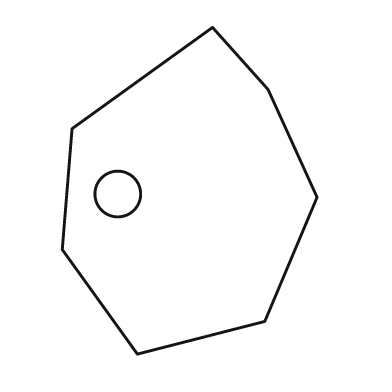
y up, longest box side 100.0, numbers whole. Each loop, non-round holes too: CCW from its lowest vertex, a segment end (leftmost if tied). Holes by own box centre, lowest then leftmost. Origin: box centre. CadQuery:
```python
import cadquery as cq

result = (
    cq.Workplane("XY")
    .moveTo(-16.0, -50.0)
    .lineTo(23.0, -40.0)
    .lineTo(39.0, -2.0)
    .lineTo(24.0, 31.0)
    .lineTo(7.0, 50.0)
    .lineTo(-36.0, 19.0)
    .lineTo(-39.0, -18.0)
    .close()
    .moveTo(-22.0, -1.0)
    .circle(7.0)
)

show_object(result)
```